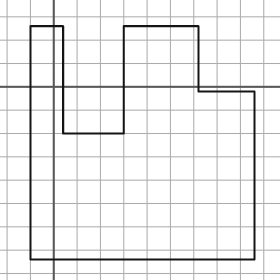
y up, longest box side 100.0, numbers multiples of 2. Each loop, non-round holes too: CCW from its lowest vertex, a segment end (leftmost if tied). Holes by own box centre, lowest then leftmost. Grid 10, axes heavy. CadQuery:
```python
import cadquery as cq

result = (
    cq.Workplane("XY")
    .moveTo(-10.0, -74.0)
    .lineTo(86.0, -74.0)
    .lineTo(86.0, -2.0)
    .lineTo(62.0, -2.0)
    .lineTo(62.0, 26.0)
    .lineTo(30.0, 26.0)
    .lineTo(30.0, -20.0)
    .lineTo(4.0, -20.0)
    .lineTo(4.0, 26.0)
    .lineTo(-10.0, 26.0)
    .close()
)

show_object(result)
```